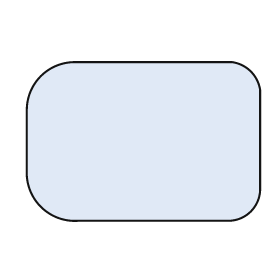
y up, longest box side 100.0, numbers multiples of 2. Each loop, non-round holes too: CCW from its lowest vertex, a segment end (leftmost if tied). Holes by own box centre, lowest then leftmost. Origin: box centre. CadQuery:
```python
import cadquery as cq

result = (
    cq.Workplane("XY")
    .moveTo(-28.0, -34.0)
    .lineTo(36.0, -34.0)
    .threePointArc((46.0, -30.0), (50.0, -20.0))
    .lineTo(50.0, 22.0)
    .threePointArc((46.0, 30.0), (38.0, 34.0))
    .lineTo(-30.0, 34.0)
    .threePointArc((-44.0, 28.0), (-50.0, 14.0))
    .lineTo(-50.0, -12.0)
    .threePointArc((-44.0, -28.0), (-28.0, -34.0))
    .close()
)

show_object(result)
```